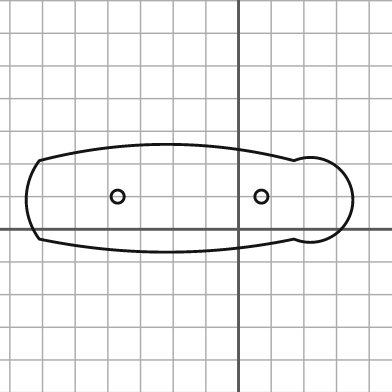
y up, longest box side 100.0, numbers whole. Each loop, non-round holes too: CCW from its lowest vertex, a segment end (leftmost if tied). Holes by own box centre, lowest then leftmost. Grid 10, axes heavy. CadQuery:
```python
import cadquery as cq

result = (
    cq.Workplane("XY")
    .moveTo(-61.0, -3.0)
    .threePointArc((-22.0, -7.0), (17.0, -3.0))
    .threePointArc((35.0, 9.0), (17.0, 21.0))
    .threePointArc((-22.0, 26.0), (-61.0, 21.0))
    .threePointArc((-65.0, 9.0), (-61.0, -3.0))
    .close()
    .moveTo(-37.0, 10.0)
    .circle(2.0)
    .moveTo(7.0, 10.0)
    .circle(2.0)
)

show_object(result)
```